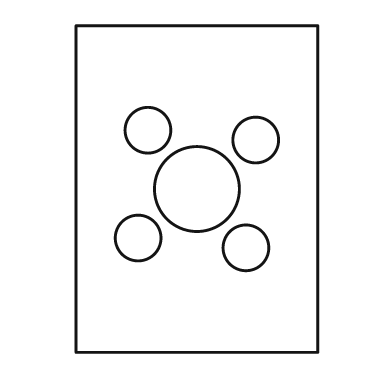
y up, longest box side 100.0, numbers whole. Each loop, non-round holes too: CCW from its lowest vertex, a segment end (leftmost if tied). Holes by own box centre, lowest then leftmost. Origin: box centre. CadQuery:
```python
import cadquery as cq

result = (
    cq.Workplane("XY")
    .moveTo(-37.0, -50.0)
    .lineTo(37.0, -50.0)
    .lineTo(37.0, 50.0)
    .lineTo(-37.0, 50.0)
    .close()
    .moveTo(15.0, -18.0)
    .circle(7.0)
    .moveTo(-18.0, -15.0)
    .circle(7.0)
    .moveTo(0.0, 0.0)
    .circle(13.0)
    .moveTo(18.0, 15.0)
    .circle(7.0)
    .moveTo(-15.0, 18.0)
    .circle(7.0)
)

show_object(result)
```